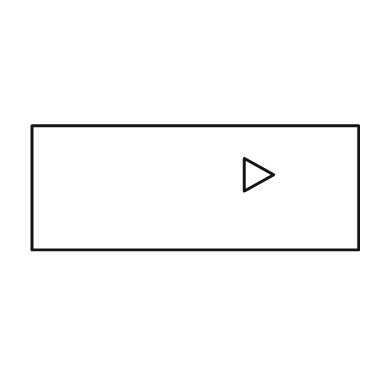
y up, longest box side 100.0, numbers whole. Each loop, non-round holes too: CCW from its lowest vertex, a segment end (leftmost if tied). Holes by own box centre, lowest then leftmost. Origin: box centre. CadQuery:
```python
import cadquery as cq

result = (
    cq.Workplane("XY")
    .moveTo(-50.0, -19.0)
    .lineTo(50.0, -19.0)
    .lineTo(50.0, 19.0)
    .lineTo(-50.0, 19.0)
    .close()
    .moveTo(15.0, -1.0)
    .lineTo(24.0, 4.0)
    .lineTo(15.0, 9.0)
    .close()
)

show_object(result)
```